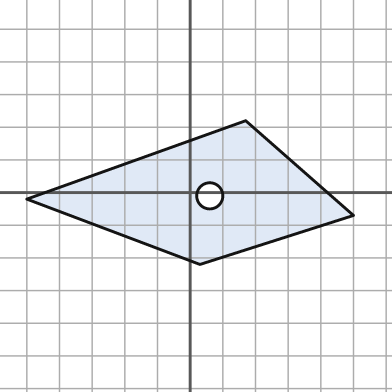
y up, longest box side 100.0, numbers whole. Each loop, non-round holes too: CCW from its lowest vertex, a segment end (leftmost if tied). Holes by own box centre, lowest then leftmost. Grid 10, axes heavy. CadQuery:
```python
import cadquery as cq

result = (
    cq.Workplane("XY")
    .moveTo(3.0, -22.0)
    .lineTo(50.0, -7.0)
    .lineTo(17.0, 22.0)
    .lineTo(-50.0, -2.0)
    .close()
    .moveTo(6.0, -1.0)
    .circle(4.0)
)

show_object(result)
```